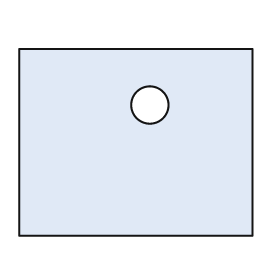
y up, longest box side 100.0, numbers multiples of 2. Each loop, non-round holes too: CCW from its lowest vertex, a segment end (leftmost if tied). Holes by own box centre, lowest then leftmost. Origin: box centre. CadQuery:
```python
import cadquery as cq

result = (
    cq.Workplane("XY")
    .moveTo(-50.0, -40.0)
    .lineTo(50.0, -40.0)
    .lineTo(50.0, 40.0)
    .lineTo(-50.0, 40.0)
    .close()
    .moveTo(6.0, 16.0)
    .circle(8.0)
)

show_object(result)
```